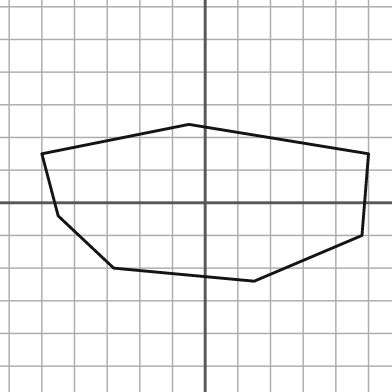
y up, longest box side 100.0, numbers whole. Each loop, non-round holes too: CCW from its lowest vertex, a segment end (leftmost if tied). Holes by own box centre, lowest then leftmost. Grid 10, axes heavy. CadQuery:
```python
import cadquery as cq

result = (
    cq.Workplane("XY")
    .moveTo(15.0, -24.0)
    .lineTo(48.0, -10.0)
    .lineTo(50.0, 15.0)
    .lineTo(-5.0, 24.0)
    .lineTo(-50.0, 15.0)
    .lineTo(-45.0, -4.0)
    .lineTo(-28.0, -20.0)
    .close()
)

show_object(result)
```